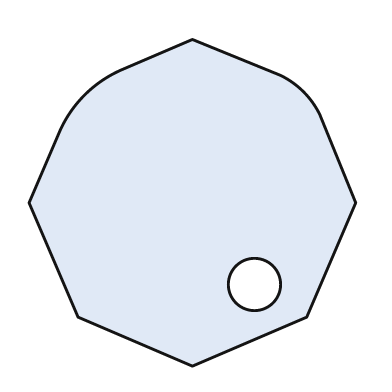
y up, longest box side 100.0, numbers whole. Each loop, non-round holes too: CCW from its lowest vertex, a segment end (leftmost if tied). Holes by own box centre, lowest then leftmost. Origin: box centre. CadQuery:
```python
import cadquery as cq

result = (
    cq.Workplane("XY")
    .moveTo(0.0, -50.0)
    .lineTo(35.0, -35.0)
    .lineTo(50.0, 0.0)
    .lineTo(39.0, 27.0)
    .threePointArc((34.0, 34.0), (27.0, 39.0))
    .lineTo(0.0, 50.0)
    .lineTo(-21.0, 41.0)
    .threePointArc((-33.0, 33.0), (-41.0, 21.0))
    .lineTo(-50.0, 0.0)
    .lineTo(-35.0, -35.0)
    .close()
    .moveTo(19.0, -25.0)
    .circle(8.0)
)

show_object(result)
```